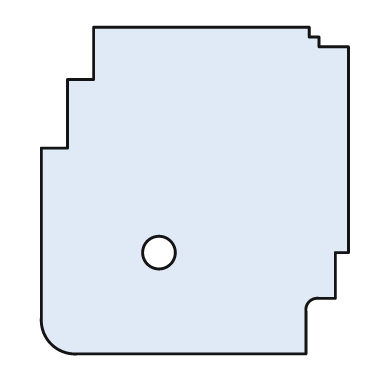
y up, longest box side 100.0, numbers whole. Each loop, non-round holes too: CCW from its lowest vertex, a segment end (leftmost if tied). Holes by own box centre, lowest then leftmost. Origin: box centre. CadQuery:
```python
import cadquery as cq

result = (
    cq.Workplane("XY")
    .moveTo(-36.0, -50.0)
    .lineTo(34.0, -50.0)
    .lineTo(34.0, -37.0)
    .threePointArc((35.0, -34.0), (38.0, -33.0))
    .lineTo(43.0, -33.0)
    .lineTo(43.0, -19.0)
    .lineTo(47.0, -19.0)
    .lineTo(47.0, 44.0)
    .lineTo(38.0, 44.0)
    .lineTo(38.0, 47.0)
    .lineTo(35.0, 47.0)
    .lineTo(35.0, 50.0)
    .lineTo(-31.0, 50.0)
    .lineTo(-31.0, 34.0)
    .lineTo(-39.0, 34.0)
    .lineTo(-39.0, 13.0)
    .lineTo(-47.0, 13.0)
    .lineTo(-47.0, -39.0)
    .threePointArc((-44.0, -47.0), (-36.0, -50.0))
    .close()
    .moveTo(-11.0, -19.0)
    .circle(5.0)
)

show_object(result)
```